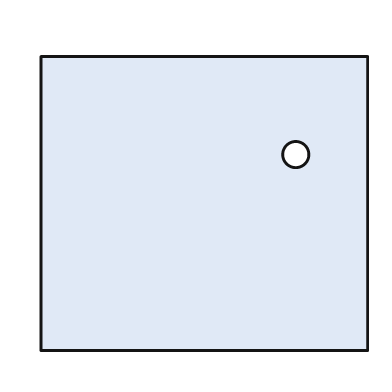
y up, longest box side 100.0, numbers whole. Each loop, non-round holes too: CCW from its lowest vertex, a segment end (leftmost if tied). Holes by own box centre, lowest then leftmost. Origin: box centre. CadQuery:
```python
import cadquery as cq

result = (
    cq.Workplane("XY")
    .moveTo(-50.0, -45.0)
    .lineTo(50.0, -45.0)
    .lineTo(50.0, 45.0)
    .lineTo(-50.0, 45.0)
    .close()
    .moveTo(28.0, 15.0)
    .circle(4.0)
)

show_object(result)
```